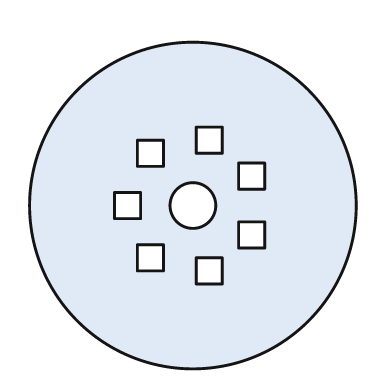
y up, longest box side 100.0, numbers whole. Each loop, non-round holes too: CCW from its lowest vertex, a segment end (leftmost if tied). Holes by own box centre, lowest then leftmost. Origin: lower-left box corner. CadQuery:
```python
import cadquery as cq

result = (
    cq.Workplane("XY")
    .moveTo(50.0, 50.0)
    .circle(50.0)
    .moveTo(51.0, 26.0)
    .lineTo(59.0, 26.0)
    .lineTo(59.0, 34.0)
    .lineTo(51.0, 34.0)
    .close()
    .moveTo(33.0, 30.0)
    .lineTo(41.0, 30.0)
    .lineTo(41.0, 38.0)
    .lineTo(33.0, 38.0)
    .close()
    .moveTo(64.0, 37.0)
    .lineTo(72.0, 37.0)
    .lineTo(72.0, 45.0)
    .lineTo(64.0, 45.0)
    .close()
    .moveTo(26.0, 46.0)
    .lineTo(34.0, 46.0)
    .lineTo(34.0, 54.0)
    .lineTo(26.0, 54.0)
    .close()
    .moveTo(50.0, 50.0)
    .circle(7.0)
    .moveTo(64.0, 55.0)
    .lineTo(72.0, 55.0)
    .lineTo(72.0, 63.0)
    .lineTo(64.0, 63.0)
    .close()
    .moveTo(33.0, 62.0)
    .lineTo(41.0, 62.0)
    .lineTo(41.0, 70.0)
    .lineTo(33.0, 70.0)
    .close()
    .moveTo(51.0, 66.0)
    .lineTo(59.0, 66.0)
    .lineTo(59.0, 74.0)
    .lineTo(51.0, 74.0)
    .close()
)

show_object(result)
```